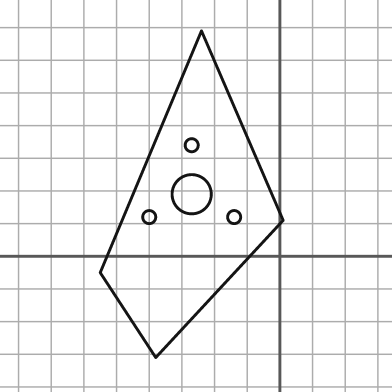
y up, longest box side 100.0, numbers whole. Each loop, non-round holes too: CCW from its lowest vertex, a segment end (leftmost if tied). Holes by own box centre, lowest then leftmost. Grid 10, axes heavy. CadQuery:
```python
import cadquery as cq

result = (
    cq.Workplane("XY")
    .moveTo(-38.0, -31.0)
    .lineTo(1.0, 11.0)
    .lineTo(-24.0, 69.0)
    .lineTo(-55.0, -5.0)
    .close()
    .moveTo(-40.0, 12.0)
    .circle(2.0)
    .moveTo(-14.0, 12.0)
    .circle(2.0)
    .moveTo(-27.0, 19.0)
    .circle(6.0)
    .moveTo(-27.0, 34.0)
    .circle(2.0)
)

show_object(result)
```